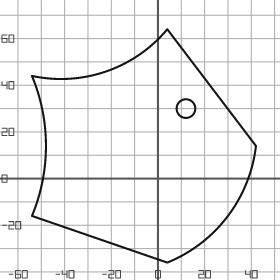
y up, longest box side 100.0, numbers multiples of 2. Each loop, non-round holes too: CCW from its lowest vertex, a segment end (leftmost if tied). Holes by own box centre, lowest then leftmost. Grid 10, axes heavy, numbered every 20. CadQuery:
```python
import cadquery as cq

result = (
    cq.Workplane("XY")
    .moveTo(4.0, -36.0)
    .threePointArc((30.0, -16.0), (42.0, 14.0))
    .lineTo(4.0, 64.0)
    .threePointArc((-22.0, 46.0), (-54.0, 44.0))
    .threePointArc((-48.0, 14.0), (-54.0, -16.0))
    .close()
    .moveTo(12.0, 30.0)
    .circle(4.0)
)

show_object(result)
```